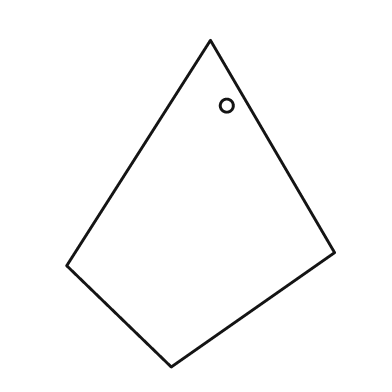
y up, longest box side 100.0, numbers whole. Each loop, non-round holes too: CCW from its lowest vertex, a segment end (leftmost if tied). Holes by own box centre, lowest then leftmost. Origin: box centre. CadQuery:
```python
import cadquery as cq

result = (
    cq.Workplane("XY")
    .moveTo(-9.0, -50.0)
    .lineTo(41.0, -15.0)
    .lineTo(3.0, 50.0)
    .lineTo(-41.0, -19.0)
    .close()
    .moveTo(8.0, 30.0)
    .circle(2.0)
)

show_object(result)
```